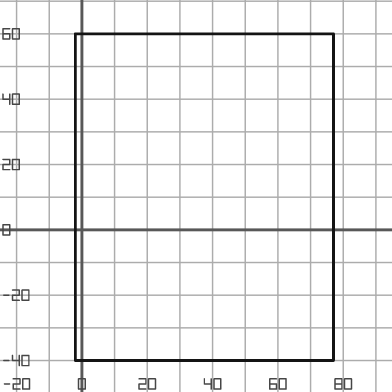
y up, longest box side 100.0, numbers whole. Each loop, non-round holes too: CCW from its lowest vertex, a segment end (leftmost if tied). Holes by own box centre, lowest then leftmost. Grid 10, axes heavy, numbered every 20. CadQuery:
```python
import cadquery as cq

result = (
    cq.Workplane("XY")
    .moveTo(-2.0, -40.0)
    .lineTo(77.0, -40.0)
    .lineTo(77.0, 60.0)
    .lineTo(-2.0, 60.0)
    .close()
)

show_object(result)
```